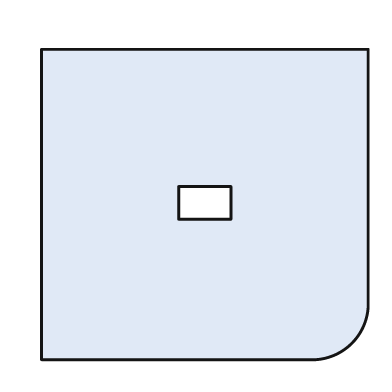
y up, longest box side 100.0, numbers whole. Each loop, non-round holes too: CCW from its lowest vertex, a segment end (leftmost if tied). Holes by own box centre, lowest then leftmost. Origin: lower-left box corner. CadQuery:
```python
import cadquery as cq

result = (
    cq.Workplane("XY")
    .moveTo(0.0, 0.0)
    .lineTo(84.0, 0.0)
    .threePointArc((95.0, 5.0), (100.0, 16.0))
    .lineTo(100.0, 95.0)
    .lineTo(0.0, 95.0)
    .close()
    .moveTo(42.0, 43.0)
    .lineTo(58.0, 43.0)
    .lineTo(58.0, 53.0)
    .lineTo(42.0, 53.0)
    .close()
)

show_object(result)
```